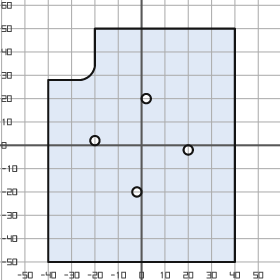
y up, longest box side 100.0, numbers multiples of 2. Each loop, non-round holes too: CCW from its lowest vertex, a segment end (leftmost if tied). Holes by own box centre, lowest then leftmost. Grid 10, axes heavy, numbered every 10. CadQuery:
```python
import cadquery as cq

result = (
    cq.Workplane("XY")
    .moveTo(-40.0, -50.0)
    .lineTo(40.0, -50.0)
    .lineTo(40.0, 50.0)
    .lineTo(-20.0, 50.0)
    .lineTo(-20.0, 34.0)
    .threePointArc((-22.0, 30.0), (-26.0, 28.0))
    .lineTo(-40.0, 28.0)
    .close()
    .moveTo(-2.0, -20.0)
    .circle(2.0)
    .moveTo(20.0, -2.0)
    .circle(2.0)
    .moveTo(-20.0, 2.0)
    .circle(2.0)
    .moveTo(2.0, 20.0)
    .circle(2.0)
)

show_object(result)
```